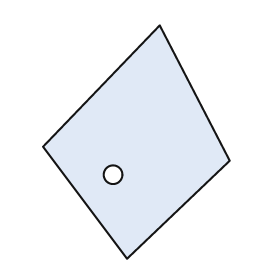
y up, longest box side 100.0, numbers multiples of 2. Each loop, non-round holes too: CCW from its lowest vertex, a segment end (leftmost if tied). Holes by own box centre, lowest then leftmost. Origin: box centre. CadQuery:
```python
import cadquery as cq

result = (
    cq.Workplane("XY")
    .moveTo(-4.0, -50.0)
    .lineTo(40.0, -8.0)
    .lineTo(10.0, 50.0)
    .lineTo(-40.0, -2.0)
    .close()
    .moveTo(-10.0, -14.0)
    .circle(4.0)
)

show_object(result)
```